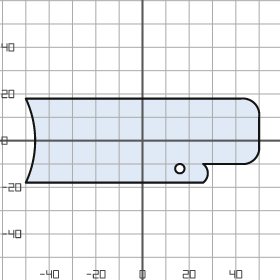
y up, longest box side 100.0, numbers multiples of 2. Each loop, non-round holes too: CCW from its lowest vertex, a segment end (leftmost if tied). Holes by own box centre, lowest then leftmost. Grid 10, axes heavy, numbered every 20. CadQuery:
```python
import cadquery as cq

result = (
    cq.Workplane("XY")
    .moveTo(-50.0, -18.0)
    .lineTo(26.0, -18.0)
    .threePointArc((28.0, -14.0), (26.0, -10.0))
    .lineTo(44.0, -10.0)
    .threePointArc((48.0, -8.0), (50.0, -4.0))
    .lineTo(50.0, 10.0)
    .threePointArc((48.0, 16.0), (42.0, 18.0))
    .lineTo(-50.0, 18.0)
    .threePointArc((-46.0, 0.0), (-50.0, -18.0))
    .close()
    .moveTo(16.0, -12.0)
    .circle(2.0)
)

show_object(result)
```